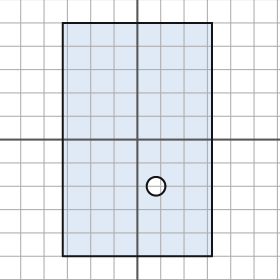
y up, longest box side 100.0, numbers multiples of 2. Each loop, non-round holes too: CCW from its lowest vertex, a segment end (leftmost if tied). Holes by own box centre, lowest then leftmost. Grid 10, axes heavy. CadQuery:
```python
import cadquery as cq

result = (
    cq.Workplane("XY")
    .moveTo(-32.0, -50.0)
    .lineTo(32.0, -50.0)
    .lineTo(32.0, 50.0)
    .lineTo(-32.0, 50.0)
    .close()
    .moveTo(8.0, -20.0)
    .circle(4.0)
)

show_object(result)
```